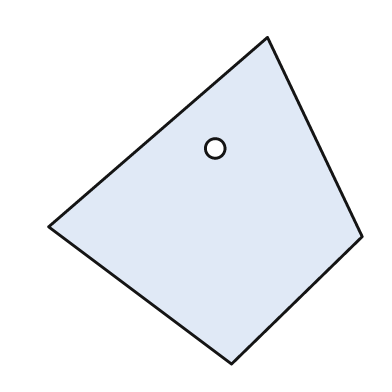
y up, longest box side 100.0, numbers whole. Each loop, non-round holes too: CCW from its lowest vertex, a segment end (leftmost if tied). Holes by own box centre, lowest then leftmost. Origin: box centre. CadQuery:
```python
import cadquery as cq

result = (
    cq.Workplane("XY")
    .moveTo(8.0, -50.0)
    .lineTo(48.0, -11.0)
    .lineTo(19.0, 50.0)
    .lineTo(-48.0, -8.0)
    .close()
    .moveTo(3.0, 16.0)
    .circle(3.0)
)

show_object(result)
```